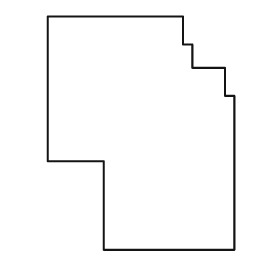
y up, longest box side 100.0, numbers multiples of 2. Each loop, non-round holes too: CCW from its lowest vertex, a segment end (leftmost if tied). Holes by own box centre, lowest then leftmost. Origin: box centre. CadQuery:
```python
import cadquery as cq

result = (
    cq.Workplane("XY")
    .moveTo(-16.0, -50.0)
    .lineTo(40.0, -50.0)
    .lineTo(40.0, 16.0)
    .lineTo(36.0, 16.0)
    .lineTo(36.0, 28.0)
    .lineTo(22.0, 28.0)
    .lineTo(22.0, 38.0)
    .lineTo(18.0, 38.0)
    .lineTo(18.0, 50.0)
    .lineTo(-40.0, 50.0)
    .lineTo(-40.0, -12.0)
    .lineTo(-16.0, -12.0)
    .close()
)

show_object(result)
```